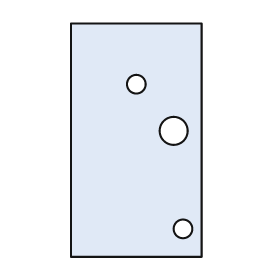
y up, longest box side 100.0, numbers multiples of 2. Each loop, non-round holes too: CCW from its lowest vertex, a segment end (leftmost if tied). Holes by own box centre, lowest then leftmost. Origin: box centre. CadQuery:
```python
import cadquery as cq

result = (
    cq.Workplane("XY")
    .moveTo(-28.0, -50.0)
    .lineTo(28.0, -50.0)
    .lineTo(28.0, 50.0)
    .lineTo(-28.0, 50.0)
    .close()
    .moveTo(20.0, -38.0)
    .circle(4.0)
    .moveTo(16.0, 4.0)
    .circle(6.0)
    .moveTo(0.0, 24.0)
    .circle(4.0)
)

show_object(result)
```